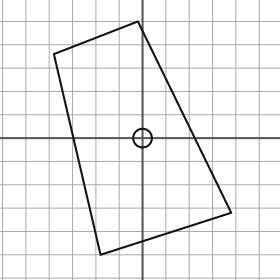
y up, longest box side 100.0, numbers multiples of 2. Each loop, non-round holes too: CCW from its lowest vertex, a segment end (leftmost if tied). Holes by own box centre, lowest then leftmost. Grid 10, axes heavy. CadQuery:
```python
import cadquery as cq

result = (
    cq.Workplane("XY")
    .moveTo(-18.0, -50.0)
    .lineTo(38.0, -32.0)
    .lineTo(-2.0, 50.0)
    .lineTo(-38.0, 36.0)
    .close()
    .moveTo(0.0, 0.0)
    .circle(4.0)
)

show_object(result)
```